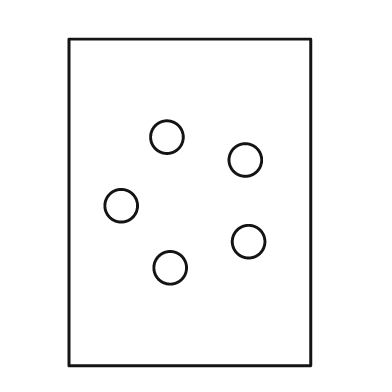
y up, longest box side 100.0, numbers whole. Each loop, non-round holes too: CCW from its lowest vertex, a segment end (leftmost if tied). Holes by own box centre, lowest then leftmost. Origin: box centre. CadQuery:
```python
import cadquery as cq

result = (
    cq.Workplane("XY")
    .moveTo(-37.0, -50.0)
    .lineTo(37.0, -50.0)
    .lineTo(37.0, 50.0)
    .lineTo(-37.0, 50.0)
    .close()
    .moveTo(-6.0, -20.0)
    .circle(5.0)
    .moveTo(18.0, -12.0)
    .circle(5.0)
    .moveTo(-21.0, -1.0)
    .circle(5.0)
    .moveTo(17.0, 13.0)
    .circle(5.0)
    .moveTo(-7.0, 20.0)
    .circle(5.0)
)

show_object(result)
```